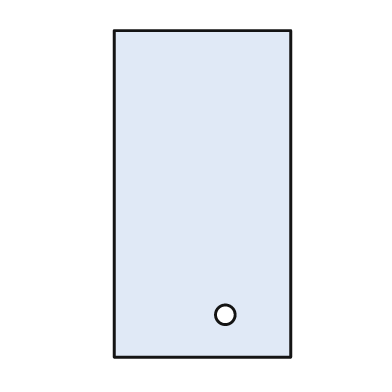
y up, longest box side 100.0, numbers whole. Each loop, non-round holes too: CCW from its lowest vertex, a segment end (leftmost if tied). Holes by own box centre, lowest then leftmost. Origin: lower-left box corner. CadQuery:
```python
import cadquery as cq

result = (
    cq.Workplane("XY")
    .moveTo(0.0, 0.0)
    .lineTo(54.0, 0.0)
    .lineTo(54.0, 100.0)
    .lineTo(0.0, 100.0)
    .close()
    .moveTo(34.0, 13.0)
    .circle(3.0)
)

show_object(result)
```